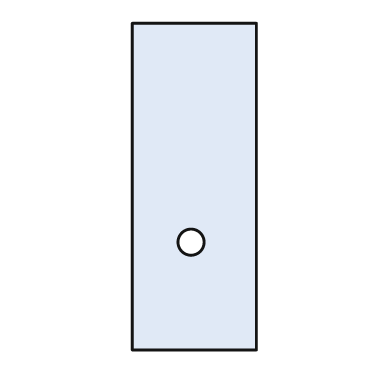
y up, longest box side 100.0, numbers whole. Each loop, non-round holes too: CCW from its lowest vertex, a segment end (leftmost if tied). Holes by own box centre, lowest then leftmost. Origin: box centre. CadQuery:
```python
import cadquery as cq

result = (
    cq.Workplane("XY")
    .moveTo(-19.0, -50.0)
    .lineTo(19.0, -50.0)
    .lineTo(19.0, 50.0)
    .lineTo(-19.0, 50.0)
    .close()
    .moveTo(-1.0, -17.0)
    .circle(4.0)
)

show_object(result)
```